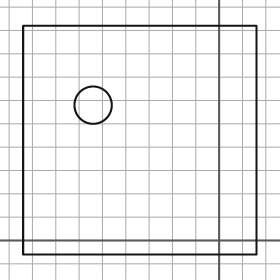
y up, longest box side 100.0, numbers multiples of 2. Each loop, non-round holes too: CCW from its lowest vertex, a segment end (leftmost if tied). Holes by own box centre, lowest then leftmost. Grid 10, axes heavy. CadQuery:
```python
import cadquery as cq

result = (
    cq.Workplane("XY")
    .moveTo(-84.0, -6.0)
    .lineTo(16.0, -6.0)
    .lineTo(16.0, 92.0)
    .lineTo(-84.0, 92.0)
    .close()
    .moveTo(-54.0, 58.0)
    .circle(8.0)
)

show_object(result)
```